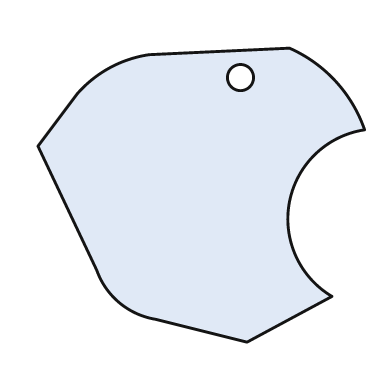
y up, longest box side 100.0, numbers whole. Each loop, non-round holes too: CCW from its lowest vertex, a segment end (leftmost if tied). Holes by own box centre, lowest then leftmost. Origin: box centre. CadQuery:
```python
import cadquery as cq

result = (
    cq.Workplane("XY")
    .moveTo(14.0, -45.0)
    .lineTo(40.0, -31.0)
    .threePointArc((27.0, -2.0), (50.0, 20.0))
    .threePointArc((41.0, 35.0), (27.0, 45.0))
    .lineTo(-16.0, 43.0)
    .threePointArc((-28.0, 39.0), (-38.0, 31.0))
    .lineTo(-50.0, 15.0)
    .lineTo(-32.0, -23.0)
    .threePointArc((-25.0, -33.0), (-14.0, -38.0))
    .close()
    .moveTo(12.0, 36.0)
    .circle(4.0)
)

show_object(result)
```